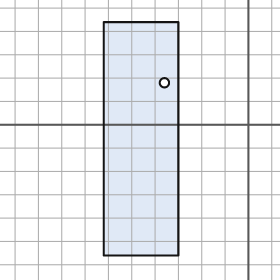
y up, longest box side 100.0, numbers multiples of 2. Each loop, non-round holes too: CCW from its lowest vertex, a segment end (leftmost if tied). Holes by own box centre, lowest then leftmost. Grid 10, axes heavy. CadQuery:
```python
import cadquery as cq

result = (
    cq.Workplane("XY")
    .moveTo(-62.0, -56.0)
    .lineTo(-30.0, -56.0)
    .lineTo(-30.0, 44.0)
    .lineTo(-62.0, 44.0)
    .close()
    .moveTo(-36.0, 18.0)
    .circle(2.0)
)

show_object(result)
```